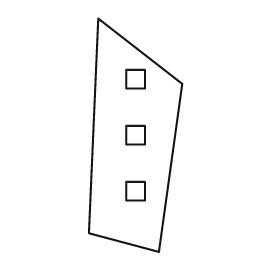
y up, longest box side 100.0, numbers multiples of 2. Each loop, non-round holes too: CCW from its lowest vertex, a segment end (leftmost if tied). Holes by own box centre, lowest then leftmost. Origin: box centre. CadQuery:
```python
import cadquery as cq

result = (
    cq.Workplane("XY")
    .moveTo(10.0, -50.0)
    .lineTo(20.0, 22.0)
    .lineTo(-16.0, 50.0)
    .lineTo(-20.0, -42.0)
    .close()
    .moveTo(-4.0, -28.0)
    .lineTo(4.0, -28.0)
    .lineTo(4.0, -20.0)
    .lineTo(-4.0, -20.0)
    .close()
    .moveTo(-4.0, -4.0)
    .lineTo(4.0, -4.0)
    .lineTo(4.0, 4.0)
    .lineTo(-4.0, 4.0)
    .close()
    .moveTo(-4.0, 20.0)
    .lineTo(4.0, 20.0)
    .lineTo(4.0, 28.0)
    .lineTo(-4.0, 28.0)
    .close()
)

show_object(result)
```